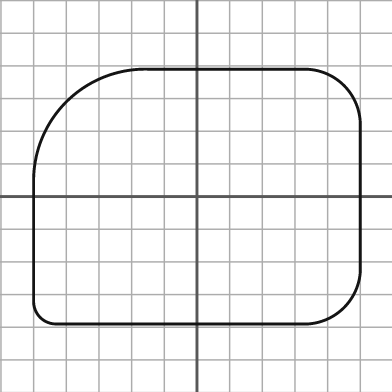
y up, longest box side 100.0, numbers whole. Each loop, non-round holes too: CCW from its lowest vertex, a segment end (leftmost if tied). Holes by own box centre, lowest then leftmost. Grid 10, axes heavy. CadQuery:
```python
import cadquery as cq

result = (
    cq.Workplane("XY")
    .moveTo(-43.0, -39.0)
    .lineTo(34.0, -39.0)
    .threePointArc((45.0, -34.0), (50.0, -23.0))
    .lineTo(50.0, 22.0)
    .threePointArc((45.0, 34.0), (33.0, 39.0))
    .lineTo(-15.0, 39.0)
    .threePointArc((-40.0, 29.0), (-50.0, 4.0))
    .lineTo(-50.0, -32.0)
    .threePointArc((-48.0, -37.0), (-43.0, -39.0))
    .close()
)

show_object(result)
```